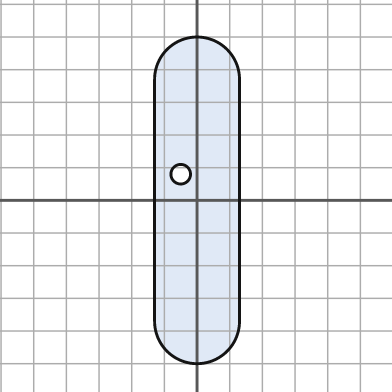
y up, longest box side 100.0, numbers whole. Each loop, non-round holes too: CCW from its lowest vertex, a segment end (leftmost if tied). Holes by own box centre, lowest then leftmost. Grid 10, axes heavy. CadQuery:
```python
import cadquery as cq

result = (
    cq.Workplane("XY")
    .moveTo(-13.0, -37.0)
    .threePointArc((0.0, -50.0), (13.0, -37.0))
    .lineTo(13.0, 37.0)
    .threePointArc((0.0, 50.0), (-13.0, 37.0))
    .close()
    .moveTo(-5.0, 8.0)
    .circle(3.0)
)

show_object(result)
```